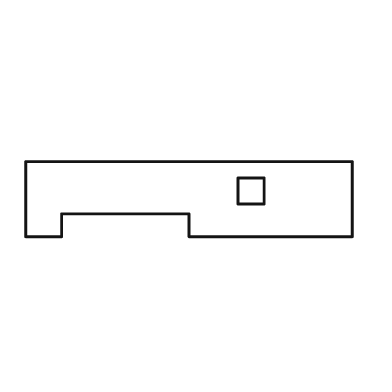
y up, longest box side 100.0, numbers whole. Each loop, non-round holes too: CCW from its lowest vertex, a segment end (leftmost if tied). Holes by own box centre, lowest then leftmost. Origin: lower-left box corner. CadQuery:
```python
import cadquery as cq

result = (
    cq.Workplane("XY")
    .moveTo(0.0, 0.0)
    .lineTo(11.0, 0.0)
    .lineTo(11.0, 7.0)
    .lineTo(50.0, 7.0)
    .lineTo(50.0, 0.0)
    .lineTo(100.0, 0.0)
    .lineTo(100.0, 23.0)
    .lineTo(0.0, 23.0)
    .close()
    .moveTo(65.0, 10.0)
    .lineTo(73.0, 10.0)
    .lineTo(73.0, 18.0)
    .lineTo(65.0, 18.0)
    .close()
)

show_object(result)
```